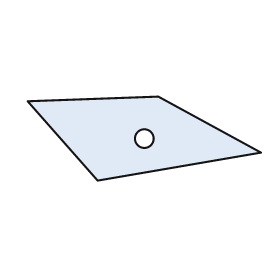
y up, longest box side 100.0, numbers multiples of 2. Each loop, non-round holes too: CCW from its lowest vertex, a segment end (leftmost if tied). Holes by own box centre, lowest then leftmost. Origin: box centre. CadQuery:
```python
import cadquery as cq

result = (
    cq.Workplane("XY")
    .moveTo(-20.0, -18.0)
    .lineTo(50.0, -6.0)
    .lineTo(6.0, 18.0)
    .lineTo(-50.0, 16.0)
    .close()
    .moveTo(0.0, 0.0)
    .circle(4.0)
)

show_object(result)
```